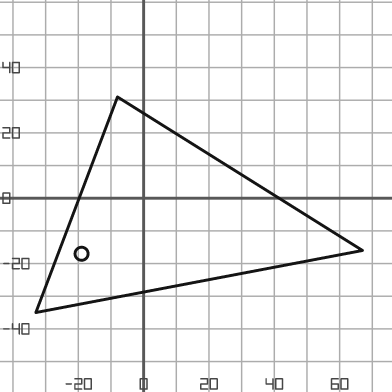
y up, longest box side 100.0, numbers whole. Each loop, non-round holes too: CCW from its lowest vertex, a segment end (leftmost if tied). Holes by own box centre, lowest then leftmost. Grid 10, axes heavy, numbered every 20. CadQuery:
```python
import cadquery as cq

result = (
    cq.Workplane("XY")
    .moveTo(-33.0, -35.0)
    .lineTo(67.0, -16.0)
    .lineTo(-8.0, 31.0)
    .close()
    .moveTo(-19.0, -17.0)
    .circle(2.0)
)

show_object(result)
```